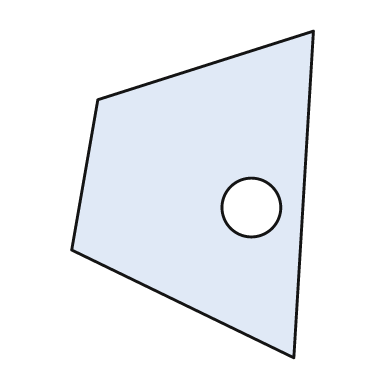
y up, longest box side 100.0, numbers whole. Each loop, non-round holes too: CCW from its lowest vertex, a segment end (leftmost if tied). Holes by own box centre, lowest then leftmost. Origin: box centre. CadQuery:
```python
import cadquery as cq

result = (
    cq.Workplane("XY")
    .moveTo(31.0, -50.0)
    .lineTo(37.0, 50.0)
    .lineTo(-29.0, 29.0)
    .lineTo(-37.0, -17.0)
    .close()
    .moveTo(18.0, -4.0)
    .circle(9.0)
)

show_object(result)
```